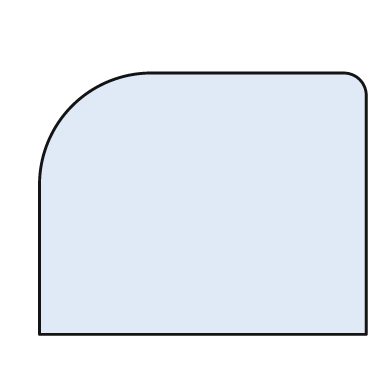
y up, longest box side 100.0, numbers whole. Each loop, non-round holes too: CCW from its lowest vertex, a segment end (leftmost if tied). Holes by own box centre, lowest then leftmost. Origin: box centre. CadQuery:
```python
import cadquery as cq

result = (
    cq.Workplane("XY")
    .moveTo(-50.0, -40.0)
    .lineTo(50.0, -40.0)
    .lineTo(50.0, 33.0)
    .threePointArc((48.0, 38.0), (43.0, 40.0))
    .lineTo(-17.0, 40.0)
    .threePointArc((-40.0, 30.0), (-50.0, 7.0))
    .close()
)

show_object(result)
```